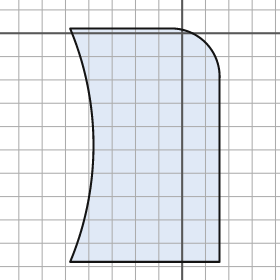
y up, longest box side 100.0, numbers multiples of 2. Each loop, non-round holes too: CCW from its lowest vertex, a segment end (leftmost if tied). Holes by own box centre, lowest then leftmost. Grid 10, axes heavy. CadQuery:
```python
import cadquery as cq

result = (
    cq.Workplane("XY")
    .moveTo(-48.0, -98.0)
    .lineTo(16.0, -98.0)
    .lineTo(16.0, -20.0)
    .threePointArc((10.0, -4.0), (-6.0, 2.0))
    .lineTo(-48.0, 2.0)
    .threePointArc((-38.0, -48.0), (-48.0, -98.0))
    .close()
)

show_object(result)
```